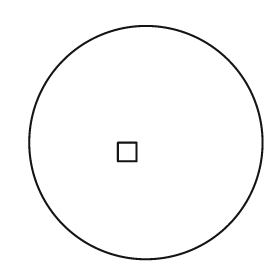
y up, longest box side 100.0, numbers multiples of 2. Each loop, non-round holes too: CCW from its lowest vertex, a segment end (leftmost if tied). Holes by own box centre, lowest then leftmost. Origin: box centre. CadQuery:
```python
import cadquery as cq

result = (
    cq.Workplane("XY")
    .moveTo(0.0, 0.0)
    .circle(50.0)
    .moveTo(-12.0, -8.0)
    .lineTo(-4.0, -8.0)
    .lineTo(-4.0, 0.0)
    .lineTo(-12.0, 0.0)
    .close()
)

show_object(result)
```